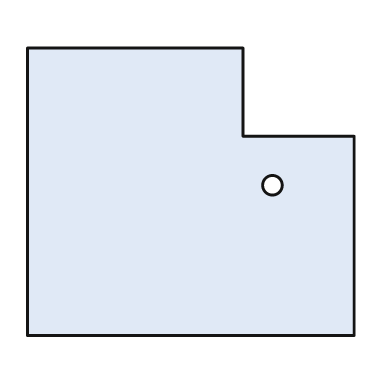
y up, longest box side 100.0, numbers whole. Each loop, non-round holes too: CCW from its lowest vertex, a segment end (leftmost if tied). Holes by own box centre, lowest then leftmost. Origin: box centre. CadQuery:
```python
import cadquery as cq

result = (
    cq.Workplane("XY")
    .moveTo(-50.0, -44.0)
    .lineTo(50.0, -44.0)
    .lineTo(50.0, 17.0)
    .lineTo(16.0, 17.0)
    .lineTo(16.0, 44.0)
    .lineTo(-50.0, 44.0)
    .close()
    .moveTo(25.0, 2.0)
    .circle(3.0)
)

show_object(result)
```